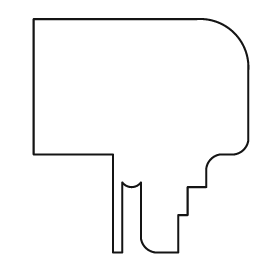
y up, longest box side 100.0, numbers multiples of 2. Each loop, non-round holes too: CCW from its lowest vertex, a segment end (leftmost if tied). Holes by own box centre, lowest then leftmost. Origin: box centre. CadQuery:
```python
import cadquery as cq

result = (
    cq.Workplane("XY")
    .moveTo(-12.0, -50.0)
    .lineTo(-8.0, -50.0)
    .lineTo(-8.0, -20.0)
    .threePointArc((-4.0, -22.0), (0.0, -20.0))
    .lineTo(0.0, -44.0)
    .threePointArc((2.0, -48.0), (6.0, -50.0))
    .lineTo(16.0, -50.0)
    .lineTo(16.0, -34.0)
    .lineTo(20.0, -34.0)
    .lineTo(20.0, -22.0)
    .lineTo(28.0, -22.0)
    .lineTo(28.0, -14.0)
    .threePointArc((30.0, -10.0), (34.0, -8.0))
    .lineTo(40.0, -8.0)
    .threePointArc((44.0, -6.0), (46.0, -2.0))
    .lineTo(46.0, 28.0)
    .threePointArc((40.0, 44.0), (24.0, 50.0))
    .lineTo(-46.0, 50.0)
    .lineTo(-46.0, -8.0)
    .lineTo(-12.0, -8.0)
    .close()
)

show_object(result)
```